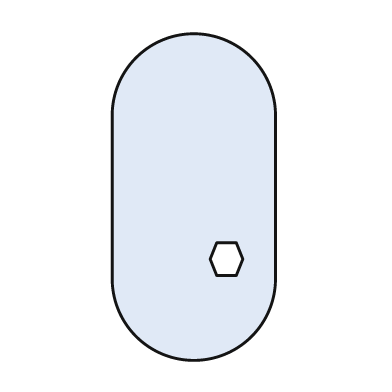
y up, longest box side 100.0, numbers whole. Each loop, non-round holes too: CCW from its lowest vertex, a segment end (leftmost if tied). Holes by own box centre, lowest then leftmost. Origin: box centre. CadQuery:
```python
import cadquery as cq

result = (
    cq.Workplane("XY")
    .moveTo(-25.0, -25.0)
    .threePointArc((0.0, -50.0), (25.0, -25.0))
    .lineTo(25.0, 25.0)
    .threePointArc((0.0, 50.0), (-25.0, 25.0))
    .close()
    .moveTo(7.0, -24.0)
    .lineTo(13.0, -24.0)
    .lineTo(15.0, -19.0)
    .lineTo(13.0, -14.0)
    .lineTo(7.0, -14.0)
    .lineTo(5.0, -19.0)
    .close()
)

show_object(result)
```